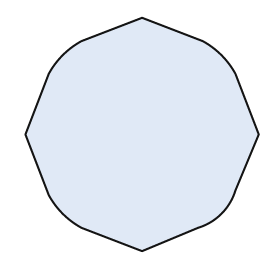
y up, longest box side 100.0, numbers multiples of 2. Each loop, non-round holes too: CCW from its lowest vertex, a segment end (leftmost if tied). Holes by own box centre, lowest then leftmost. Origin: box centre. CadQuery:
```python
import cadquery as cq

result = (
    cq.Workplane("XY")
    .moveTo(0.0, -50.0)
    .lineTo(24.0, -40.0)
    .threePointArc((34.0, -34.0), (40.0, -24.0))
    .lineTo(50.0, 0.0)
    .lineTo(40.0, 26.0)
    .threePointArc((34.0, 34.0), (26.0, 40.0))
    .lineTo(0.0, 50.0)
    .lineTo(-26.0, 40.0)
    .threePointArc((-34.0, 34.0), (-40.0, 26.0))
    .lineTo(-50.0, 0.0)
    .lineTo(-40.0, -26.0)
    .threePointArc((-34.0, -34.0), (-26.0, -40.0))
    .close()
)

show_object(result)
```